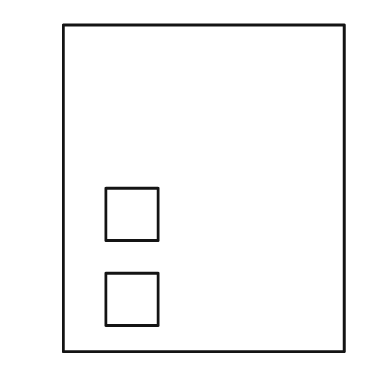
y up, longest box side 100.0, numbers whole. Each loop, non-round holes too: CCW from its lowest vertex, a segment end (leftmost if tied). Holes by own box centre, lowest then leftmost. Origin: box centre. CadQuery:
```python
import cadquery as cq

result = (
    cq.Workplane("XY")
    .moveTo(-43.0, -50.0)
    .lineTo(43.0, -50.0)
    .lineTo(43.0, 50.0)
    .lineTo(-43.0, 50.0)
    .close()
    .moveTo(-30.0, -42.0)
    .lineTo(-14.0, -42.0)
    .lineTo(-14.0, -26.0)
    .lineTo(-30.0, -26.0)
    .close()
    .moveTo(-30.0, -16.0)
    .lineTo(-14.0, -16.0)
    .lineTo(-14.0, 0.0)
    .lineTo(-30.0, 0.0)
    .close()
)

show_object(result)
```